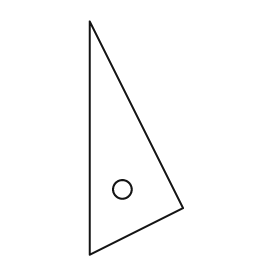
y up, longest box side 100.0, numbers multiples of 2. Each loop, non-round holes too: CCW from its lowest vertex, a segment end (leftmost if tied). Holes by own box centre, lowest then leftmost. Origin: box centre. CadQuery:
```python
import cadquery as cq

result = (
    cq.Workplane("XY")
    .moveTo(-20.0, -50.0)
    .lineTo(20.0, -30.0)
    .lineTo(-20.0, 50.0)
    .close()
    .moveTo(-6.0, -22.0)
    .circle(4.0)
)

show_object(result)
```